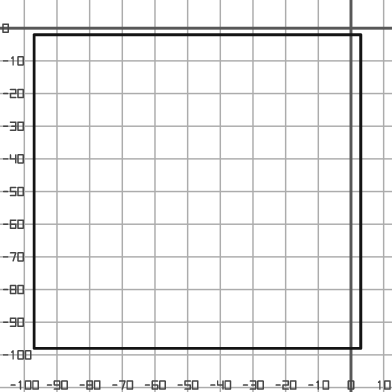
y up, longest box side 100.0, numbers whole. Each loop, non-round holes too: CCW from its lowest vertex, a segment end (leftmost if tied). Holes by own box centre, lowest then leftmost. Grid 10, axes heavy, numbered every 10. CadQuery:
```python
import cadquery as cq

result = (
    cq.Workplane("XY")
    .moveTo(-97.0, -98.0)
    .lineTo(3.0, -98.0)
    .lineTo(3.0, -2.0)
    .lineTo(-97.0, -2.0)
    .close()
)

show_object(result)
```